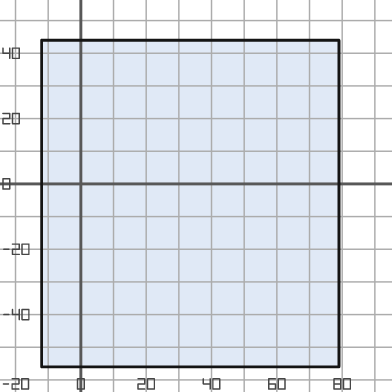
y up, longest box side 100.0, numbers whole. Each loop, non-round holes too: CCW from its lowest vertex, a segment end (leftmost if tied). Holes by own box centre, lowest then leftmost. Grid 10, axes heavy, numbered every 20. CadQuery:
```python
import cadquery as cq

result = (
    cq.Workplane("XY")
    .moveTo(-12.0, -56.0)
    .lineTo(79.0, -56.0)
    .lineTo(79.0, 44.0)
    .lineTo(-12.0, 44.0)
    .close()
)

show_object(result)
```